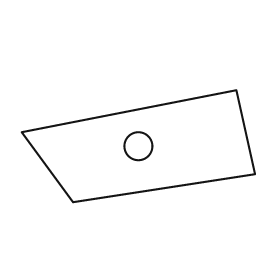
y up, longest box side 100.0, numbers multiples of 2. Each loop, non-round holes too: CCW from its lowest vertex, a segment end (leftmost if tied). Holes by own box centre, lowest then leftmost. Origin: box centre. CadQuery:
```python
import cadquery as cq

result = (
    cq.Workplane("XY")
    .moveTo(-28.0, -24.0)
    .lineTo(50.0, -12.0)
    .lineTo(42.0, 24.0)
    .lineTo(-50.0, 6.0)
    .close()
    .moveTo(0.0, 0.0)
    .circle(6.0)
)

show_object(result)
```